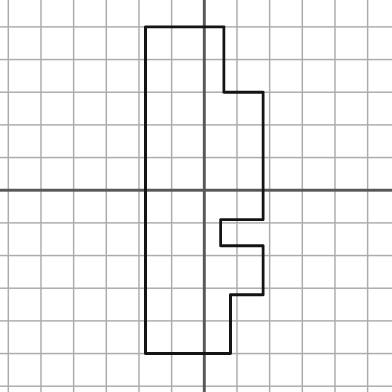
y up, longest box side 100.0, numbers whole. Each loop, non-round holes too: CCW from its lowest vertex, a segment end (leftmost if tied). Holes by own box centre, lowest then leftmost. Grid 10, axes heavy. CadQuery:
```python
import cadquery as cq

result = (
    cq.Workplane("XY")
    .moveTo(-18.0, -50.0)
    .lineTo(8.0, -50.0)
    .lineTo(8.0, -32.0)
    .lineTo(18.0, -32.0)
    .lineTo(18.0, -17.0)
    .lineTo(5.0, -17.0)
    .lineTo(5.0, -9.0)
    .lineTo(18.0, -9.0)
    .lineTo(18.0, 30.0)
    .lineTo(6.0, 30.0)
    .lineTo(6.0, 50.0)
    .lineTo(-18.0, 50.0)
    .close()
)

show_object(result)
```